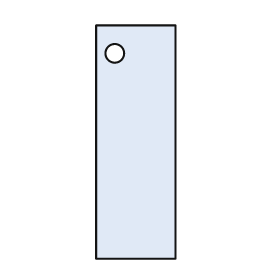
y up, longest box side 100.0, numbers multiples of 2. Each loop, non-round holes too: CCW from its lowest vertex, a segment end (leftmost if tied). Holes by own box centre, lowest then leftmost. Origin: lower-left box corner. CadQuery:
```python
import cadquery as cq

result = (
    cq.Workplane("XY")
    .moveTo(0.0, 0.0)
    .lineTo(34.0, 0.0)
    .lineTo(34.0, 100.0)
    .lineTo(0.0, 100.0)
    .close()
    .moveTo(8.0, 88.0)
    .circle(4.0)
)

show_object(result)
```